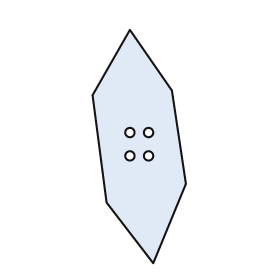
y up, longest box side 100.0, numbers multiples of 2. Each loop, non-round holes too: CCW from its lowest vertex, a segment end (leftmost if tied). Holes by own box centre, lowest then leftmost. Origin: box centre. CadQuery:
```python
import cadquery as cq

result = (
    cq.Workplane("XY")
    .moveTo(6.0, -50.0)
    .lineTo(20.0, -16.0)
    .lineTo(14.0, 24.0)
    .lineTo(-4.0, 50.0)
    .lineTo(-20.0, 22.0)
    .lineTo(-14.0, -24.0)
    .close()
    .moveTo(-4.0, -4.0)
    .circle(2.0)
    .moveTo(4.0, -4.0)
    .circle(2.0)
    .moveTo(-4.0, 6.0)
    .circle(2.0)
    .moveTo(4.0, 6.0)
    .circle(2.0)
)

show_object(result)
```